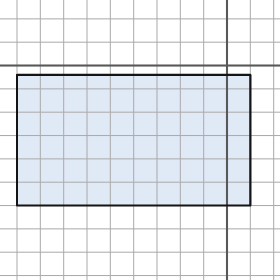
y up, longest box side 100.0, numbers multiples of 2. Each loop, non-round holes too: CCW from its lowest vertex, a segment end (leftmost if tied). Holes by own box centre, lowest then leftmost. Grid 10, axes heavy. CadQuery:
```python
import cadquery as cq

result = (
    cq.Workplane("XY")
    .moveTo(-90.0, -60.0)
    .lineTo(10.0, -60.0)
    .lineTo(10.0, -4.0)
    .lineTo(-90.0, -4.0)
    .close()
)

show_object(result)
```